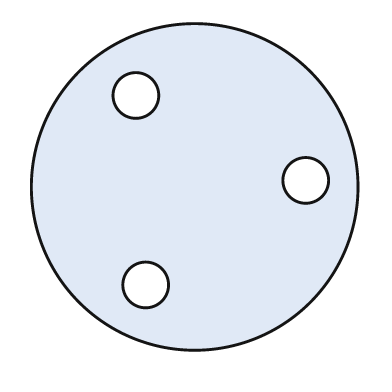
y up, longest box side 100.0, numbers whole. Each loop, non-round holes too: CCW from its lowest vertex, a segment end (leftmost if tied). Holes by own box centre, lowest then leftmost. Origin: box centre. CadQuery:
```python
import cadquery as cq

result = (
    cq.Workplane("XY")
    .moveTo(0.0, 0.0)
    .circle(50.0)
    .moveTo(-15.0, -30.0)
    .circle(7.0)
    .moveTo(34.0, 2.0)
    .circle(7.0)
    .moveTo(-18.0, 28.0)
    .circle(7.0)
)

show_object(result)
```